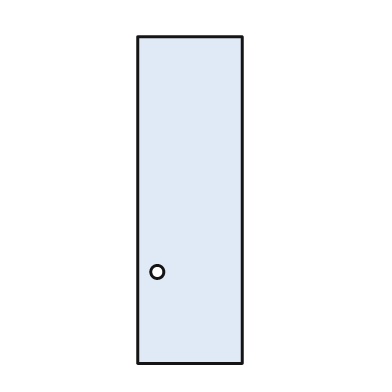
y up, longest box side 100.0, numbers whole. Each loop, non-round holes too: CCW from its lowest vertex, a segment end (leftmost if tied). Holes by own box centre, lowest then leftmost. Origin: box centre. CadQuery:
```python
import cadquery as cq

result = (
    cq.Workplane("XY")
    .moveTo(-16.0, -50.0)
    .lineTo(16.0, -50.0)
    .lineTo(16.0, 50.0)
    .lineTo(-16.0, 50.0)
    .close()
    .moveTo(-10.0, -22.0)
    .circle(2.0)
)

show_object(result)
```